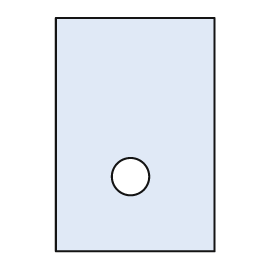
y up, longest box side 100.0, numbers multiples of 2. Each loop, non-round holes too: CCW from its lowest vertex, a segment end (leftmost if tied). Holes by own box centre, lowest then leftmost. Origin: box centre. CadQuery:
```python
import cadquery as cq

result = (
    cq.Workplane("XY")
    .moveTo(-34.0, -50.0)
    .lineTo(34.0, -50.0)
    .lineTo(34.0, 50.0)
    .lineTo(-34.0, 50.0)
    .close()
    .moveTo(-2.0, -18.0)
    .circle(8.0)
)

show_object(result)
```